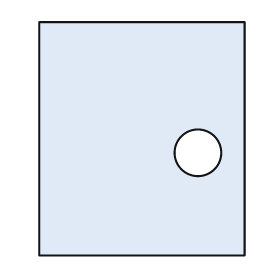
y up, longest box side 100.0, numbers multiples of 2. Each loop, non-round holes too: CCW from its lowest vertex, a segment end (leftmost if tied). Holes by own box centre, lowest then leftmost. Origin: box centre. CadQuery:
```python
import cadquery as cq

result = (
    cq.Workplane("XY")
    .moveTo(-44.0, -50.0)
    .lineTo(44.0, -50.0)
    .lineTo(44.0, 50.0)
    .lineTo(-44.0, 50.0)
    .close()
    .moveTo(24.0, -6.0)
    .circle(10.0)
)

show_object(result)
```